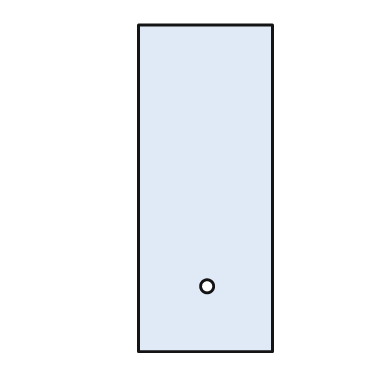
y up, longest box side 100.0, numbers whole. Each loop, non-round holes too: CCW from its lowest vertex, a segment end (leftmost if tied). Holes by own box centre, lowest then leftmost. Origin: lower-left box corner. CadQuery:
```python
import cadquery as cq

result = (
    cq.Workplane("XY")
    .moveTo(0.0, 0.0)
    .lineTo(41.0, 0.0)
    .lineTo(41.0, 100.0)
    .lineTo(0.0, 100.0)
    .close()
    .moveTo(21.0, 20.0)
    .circle(2.0)
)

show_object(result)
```